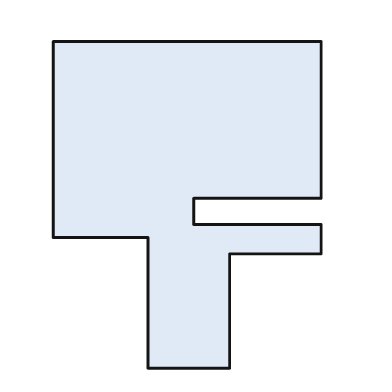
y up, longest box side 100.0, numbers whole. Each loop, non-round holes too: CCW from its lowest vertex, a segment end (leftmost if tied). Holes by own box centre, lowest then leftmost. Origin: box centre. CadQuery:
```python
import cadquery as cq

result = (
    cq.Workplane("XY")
    .moveTo(-12.0, -50.0)
    .lineTo(13.0, -50.0)
    .lineTo(13.0, -15.0)
    .lineTo(41.0, -15.0)
    .lineTo(41.0, -6.0)
    .lineTo(2.0, -6.0)
    .lineTo(2.0, 2.0)
    .lineTo(41.0, 2.0)
    .lineTo(41.0, 50.0)
    .lineTo(-41.0, 50.0)
    .lineTo(-41.0, -10.0)
    .lineTo(-12.0, -10.0)
    .close()
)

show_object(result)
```